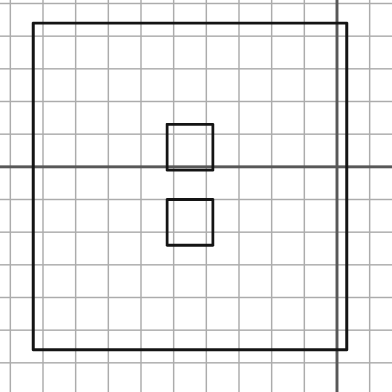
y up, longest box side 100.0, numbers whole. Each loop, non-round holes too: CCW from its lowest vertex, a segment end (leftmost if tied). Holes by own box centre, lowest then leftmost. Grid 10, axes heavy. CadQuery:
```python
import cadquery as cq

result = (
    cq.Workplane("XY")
    .moveTo(-93.0, -56.0)
    .lineTo(3.0, -56.0)
    .lineTo(3.0, 44.0)
    .lineTo(-93.0, 44.0)
    .close()
    .moveTo(-52.0, -24.0)
    .lineTo(-38.0, -24.0)
    .lineTo(-38.0, -10.0)
    .lineTo(-52.0, -10.0)
    .close()
    .moveTo(-52.0, -1.0)
    .lineTo(-38.0, -1.0)
    .lineTo(-38.0, 13.0)
    .lineTo(-52.0, 13.0)
    .close()
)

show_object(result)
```